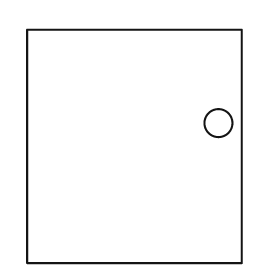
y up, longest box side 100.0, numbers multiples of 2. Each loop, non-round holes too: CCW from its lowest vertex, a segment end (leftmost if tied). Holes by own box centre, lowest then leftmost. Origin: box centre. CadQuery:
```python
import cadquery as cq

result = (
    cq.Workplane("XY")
    .moveTo(-46.0, -50.0)
    .lineTo(46.0, -50.0)
    .lineTo(46.0, 50.0)
    .lineTo(-46.0, 50.0)
    .close()
    .moveTo(36.0, 10.0)
    .circle(6.0)
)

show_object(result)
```